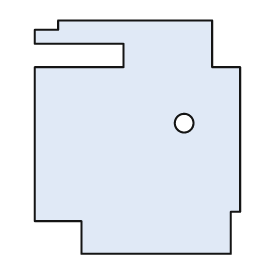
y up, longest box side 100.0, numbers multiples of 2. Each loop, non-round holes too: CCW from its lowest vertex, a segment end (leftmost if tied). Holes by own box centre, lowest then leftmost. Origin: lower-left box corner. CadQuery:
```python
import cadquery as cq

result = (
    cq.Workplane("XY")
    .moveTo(20.0, 0.0)
    .lineTo(84.0, 0.0)
    .lineTo(84.0, 18.0)
    .lineTo(88.0, 18.0)
    .lineTo(88.0, 80.0)
    .lineTo(76.0, 80.0)
    .lineTo(76.0, 100.0)
    .lineTo(10.0, 100.0)
    .lineTo(10.0, 96.0)
    .lineTo(0.0, 96.0)
    .lineTo(0.0, 90.0)
    .lineTo(38.0, 90.0)
    .lineTo(38.0, 80.0)
    .lineTo(0.0, 80.0)
    .lineTo(0.0, 14.0)
    .lineTo(20.0, 14.0)
    .close()
    .moveTo(64.0, 56.0)
    .circle(4.0)
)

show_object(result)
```